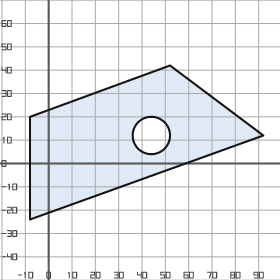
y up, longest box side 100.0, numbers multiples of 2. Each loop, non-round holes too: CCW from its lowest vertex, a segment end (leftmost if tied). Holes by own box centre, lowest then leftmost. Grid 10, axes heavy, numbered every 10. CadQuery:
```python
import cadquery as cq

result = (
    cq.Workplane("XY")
    .moveTo(-8.0, -24.0)
    .lineTo(92.0, 12.0)
    .lineTo(52.0, 42.0)
    .lineTo(-8.0, 20.0)
    .close()
    .moveTo(44.0, 12.0)
    .circle(8.0)
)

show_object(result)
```